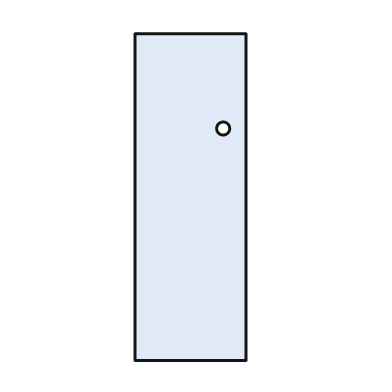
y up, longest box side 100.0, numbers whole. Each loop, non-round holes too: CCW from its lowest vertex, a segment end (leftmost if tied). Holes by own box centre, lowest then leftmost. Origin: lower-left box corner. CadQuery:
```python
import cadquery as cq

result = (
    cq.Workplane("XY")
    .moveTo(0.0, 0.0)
    .lineTo(34.0, 0.0)
    .lineTo(34.0, 100.0)
    .lineTo(0.0, 100.0)
    .close()
    .moveTo(27.0, 71.0)
    .circle(2.0)
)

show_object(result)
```